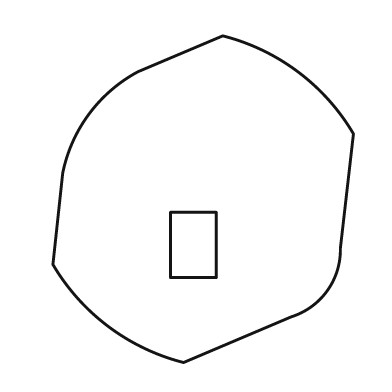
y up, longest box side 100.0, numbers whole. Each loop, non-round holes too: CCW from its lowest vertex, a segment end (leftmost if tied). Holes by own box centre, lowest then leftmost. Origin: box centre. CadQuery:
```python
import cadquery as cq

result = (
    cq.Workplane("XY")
    .moveTo(-6.0, -50.0)
    .lineTo(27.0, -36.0)
    .threePointArc((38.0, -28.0), (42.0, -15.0))
    .lineTo(46.0, 20.0)
    .threePointArc((29.0, 39.0), (6.0, 50.0))
    .lineTo(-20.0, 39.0)
    .threePointArc((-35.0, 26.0), (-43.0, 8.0))
    .lineTo(-46.0, -20.0)
    .threePointArc((-29.0, -39.0), (-6.0, -50.0))
    .close()
    .moveTo(-10.0, -24.0)
    .lineTo(4.0, -24.0)
    .lineTo(4.0, -4.0)
    .lineTo(-10.0, -4.0)
    .close()
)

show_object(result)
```